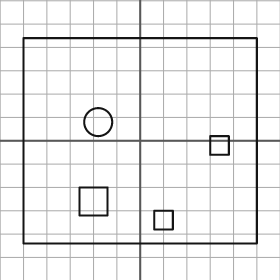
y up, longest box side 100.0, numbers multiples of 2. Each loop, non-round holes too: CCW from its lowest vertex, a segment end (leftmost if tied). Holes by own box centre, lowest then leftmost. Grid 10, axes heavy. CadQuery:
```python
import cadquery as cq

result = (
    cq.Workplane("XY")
    .moveTo(-50.0, -44.0)
    .lineTo(50.0, -44.0)
    .lineTo(50.0, 44.0)
    .lineTo(-50.0, 44.0)
    .close()
    .moveTo(6.0, -38.0)
    .lineTo(14.0, -38.0)
    .lineTo(14.0, -30.0)
    .lineTo(6.0, -30.0)
    .close()
    .moveTo(-26.0, -32.0)
    .lineTo(-14.0, -32.0)
    .lineTo(-14.0, -20.0)
    .lineTo(-26.0, -20.0)
    .close()
    .moveTo(30.0, -6.0)
    .lineTo(38.0, -6.0)
    .lineTo(38.0, 2.0)
    .lineTo(30.0, 2.0)
    .close()
    .moveTo(-18.0, 8.0)
    .circle(6.0)
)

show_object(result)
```